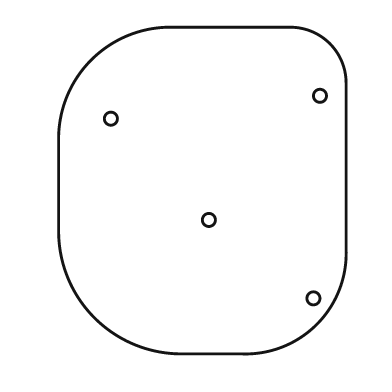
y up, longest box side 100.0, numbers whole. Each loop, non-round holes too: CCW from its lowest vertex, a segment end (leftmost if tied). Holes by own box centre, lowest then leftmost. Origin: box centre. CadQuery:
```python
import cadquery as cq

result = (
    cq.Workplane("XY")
    .moveTo(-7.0, -50.0)
    .lineTo(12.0, -50.0)
    .threePointArc((35.0, -41.0), (44.0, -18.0))
    .lineTo(44.0, 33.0)
    .threePointArc((39.0, 45.0), (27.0, 50.0))
    .lineTo(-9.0, 50.0)
    .threePointArc((-34.0, 40.0), (-44.0, 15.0))
    .lineTo(-44.0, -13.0)
    .threePointArc((-33.0, -39.0), (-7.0, -50.0))
    .close()
    .moveTo(34.0, -33.0)
    .circle(2.0)
    .moveTo(2.0, -9.0)
    .circle(2.0)
    .moveTo(-28.0, 22.0)
    .circle(2.0)
    .moveTo(36.0, 29.0)
    .circle(2.0)
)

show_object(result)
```